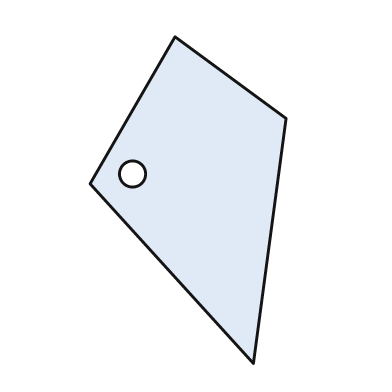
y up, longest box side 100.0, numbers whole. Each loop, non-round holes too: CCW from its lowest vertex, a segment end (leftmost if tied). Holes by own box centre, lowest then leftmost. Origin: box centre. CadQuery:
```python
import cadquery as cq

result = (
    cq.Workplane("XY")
    .moveTo(20.0, -50.0)
    .lineTo(30.0, 25.0)
    .lineTo(-4.0, 50.0)
    .lineTo(-30.0, 5.0)
    .close()
    .moveTo(-17.0, 8.0)
    .circle(4.0)
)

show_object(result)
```